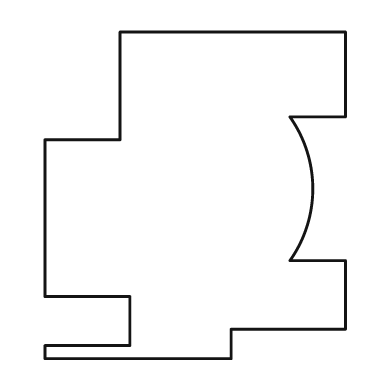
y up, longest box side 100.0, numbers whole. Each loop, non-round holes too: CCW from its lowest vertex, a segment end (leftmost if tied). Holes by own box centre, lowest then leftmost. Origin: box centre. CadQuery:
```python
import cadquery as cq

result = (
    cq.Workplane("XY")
    .moveTo(-46.0, -50.0)
    .lineTo(11.0, -50.0)
    .lineTo(11.0, -41.0)
    .lineTo(46.0, -41.0)
    .lineTo(46.0, -20.0)
    .lineTo(29.0, -20.0)
    .threePointArc((36.0, 2.0), (29.0, 24.0))
    .lineTo(46.0, 24.0)
    .lineTo(46.0, 50.0)
    .lineTo(-23.0, 50.0)
    .lineTo(-23.0, 17.0)
    .lineTo(-46.0, 17.0)
    .lineTo(-46.0, -31.0)
    .lineTo(-20.0, -31.0)
    .lineTo(-20.0, -46.0)
    .lineTo(-46.0, -46.0)
    .close()
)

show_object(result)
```